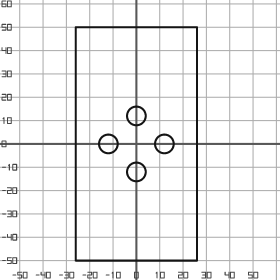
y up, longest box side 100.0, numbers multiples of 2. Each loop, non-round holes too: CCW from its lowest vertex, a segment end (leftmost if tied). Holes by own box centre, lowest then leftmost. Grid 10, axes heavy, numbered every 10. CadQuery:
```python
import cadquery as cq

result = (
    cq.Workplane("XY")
    .moveTo(-26.0, -50.0)
    .lineTo(26.0, -50.0)
    .lineTo(26.0, 50.0)
    .lineTo(-26.0, 50.0)
    .close()
    .moveTo(0.0, -12.0)
    .circle(4.0)
    .moveTo(-12.0, 0.0)
    .circle(4.0)
    .moveTo(12.0, 0.0)
    .circle(4.0)
    .moveTo(0.0, 12.0)
    .circle(4.0)
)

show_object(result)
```